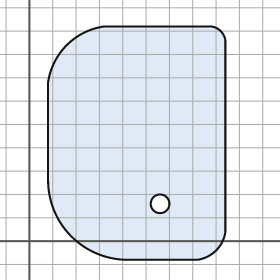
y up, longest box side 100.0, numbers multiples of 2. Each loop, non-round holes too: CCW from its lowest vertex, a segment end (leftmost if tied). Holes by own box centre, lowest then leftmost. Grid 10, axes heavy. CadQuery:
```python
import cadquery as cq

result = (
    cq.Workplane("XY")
    .moveTo(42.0, -8.0)
    .lineTo(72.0, -8.0)
    .threePointArc((80.0, -4.0), (84.0, 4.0))
    .lineTo(84.0, 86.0)
    .threePointArc((82.0, 90.0), (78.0, 92.0))
    .lineTo(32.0, 92.0)
    .threePointArc((16.0, 84.0), (8.0, 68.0))
    .lineTo(8.0, 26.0)
    .threePointArc((18.0, 2.0), (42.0, -8.0))
    .close()
    .moveTo(56.0, 16.0)
    .circle(4.0)
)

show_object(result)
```